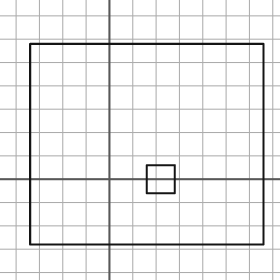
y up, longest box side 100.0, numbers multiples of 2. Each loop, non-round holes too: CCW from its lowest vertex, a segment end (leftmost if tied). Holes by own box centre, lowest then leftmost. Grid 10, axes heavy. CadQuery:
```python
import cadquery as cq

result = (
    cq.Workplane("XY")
    .moveTo(-34.0, -28.0)
    .lineTo(66.0, -28.0)
    .lineTo(66.0, 58.0)
    .lineTo(-34.0, 58.0)
    .close()
    .moveTo(16.0, -6.0)
    .lineTo(28.0, -6.0)
    .lineTo(28.0, 6.0)
    .lineTo(16.0, 6.0)
    .close()
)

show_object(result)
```